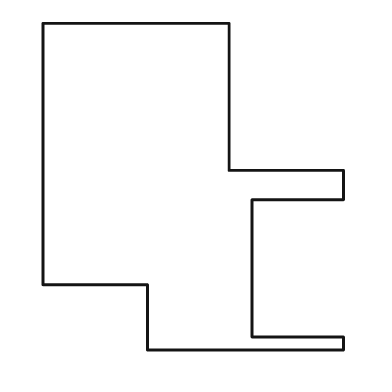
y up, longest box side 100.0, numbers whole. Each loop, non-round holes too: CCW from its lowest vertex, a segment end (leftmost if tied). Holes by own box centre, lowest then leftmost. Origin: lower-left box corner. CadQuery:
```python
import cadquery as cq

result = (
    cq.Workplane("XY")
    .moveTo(32.0, 0.0)
    .lineTo(92.0, 0.0)
    .lineTo(92.0, 4.0)
    .lineTo(64.0, 4.0)
    .lineTo(64.0, 46.0)
    .lineTo(92.0, 46.0)
    .lineTo(92.0, 55.0)
    .lineTo(57.0, 55.0)
    .lineTo(57.0, 100.0)
    .lineTo(0.0, 100.0)
    .lineTo(0.0, 20.0)
    .lineTo(32.0, 20.0)
    .close()
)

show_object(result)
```